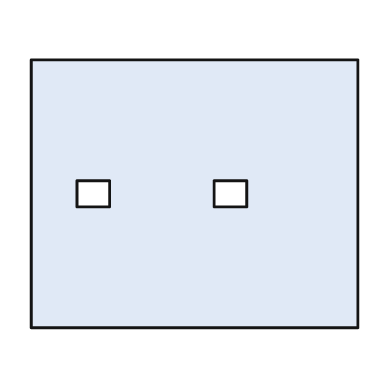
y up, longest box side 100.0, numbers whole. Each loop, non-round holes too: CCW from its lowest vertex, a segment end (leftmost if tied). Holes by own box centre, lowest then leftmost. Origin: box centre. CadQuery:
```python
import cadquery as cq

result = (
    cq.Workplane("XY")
    .moveTo(-50.0, -41.0)
    .lineTo(50.0, -41.0)
    .lineTo(50.0, 41.0)
    .lineTo(-50.0, 41.0)
    .close()
    .moveTo(-36.0, -4.0)
    .lineTo(-26.0, -4.0)
    .lineTo(-26.0, 4.0)
    .lineTo(-36.0, 4.0)
    .close()
    .moveTo(6.0, -4.0)
    .lineTo(16.0, -4.0)
    .lineTo(16.0, 4.0)
    .lineTo(6.0, 4.0)
    .close()
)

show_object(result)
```